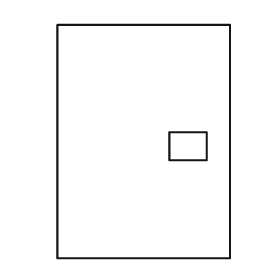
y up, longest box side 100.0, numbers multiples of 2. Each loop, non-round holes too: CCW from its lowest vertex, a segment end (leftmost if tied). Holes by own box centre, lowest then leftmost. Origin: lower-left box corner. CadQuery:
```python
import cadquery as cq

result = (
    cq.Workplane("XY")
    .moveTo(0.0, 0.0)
    .lineTo(74.0, 0.0)
    .lineTo(74.0, 100.0)
    .lineTo(0.0, 100.0)
    .close()
    .moveTo(48.0, 42.0)
    .lineTo(64.0, 42.0)
    .lineTo(64.0, 54.0)
    .lineTo(48.0, 54.0)
    .close()
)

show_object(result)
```